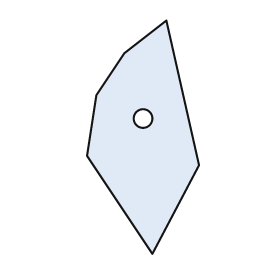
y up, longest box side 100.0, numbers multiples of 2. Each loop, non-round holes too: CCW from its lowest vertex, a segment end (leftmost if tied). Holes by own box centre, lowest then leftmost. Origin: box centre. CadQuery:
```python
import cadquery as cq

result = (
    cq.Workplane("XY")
    .moveTo(4.0, -50.0)
    .lineTo(24.0, -12.0)
    .lineTo(10.0, 50.0)
    .lineTo(-8.0, 36.0)
    .lineTo(-20.0, 18.0)
    .lineTo(-24.0, -8.0)
    .close()
    .moveTo(0.0, 8.0)
    .circle(4.0)
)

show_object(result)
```